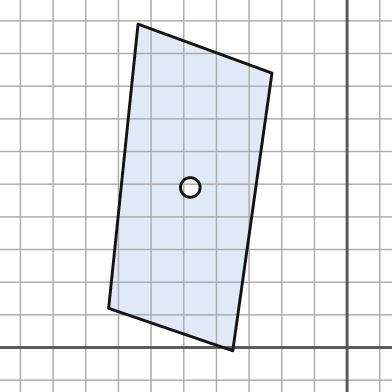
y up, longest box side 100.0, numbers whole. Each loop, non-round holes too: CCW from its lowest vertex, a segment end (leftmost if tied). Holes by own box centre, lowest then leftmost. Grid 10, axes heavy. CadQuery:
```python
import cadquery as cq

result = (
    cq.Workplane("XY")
    .moveTo(-35.0, -1.0)
    .lineTo(-23.0, 84.0)
    .lineTo(-64.0, 99.0)
    .lineTo(-73.0, 12.0)
    .close()
    .moveTo(-48.0, 49.0)
    .circle(3.0)
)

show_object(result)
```